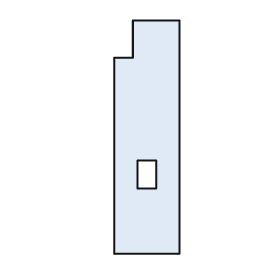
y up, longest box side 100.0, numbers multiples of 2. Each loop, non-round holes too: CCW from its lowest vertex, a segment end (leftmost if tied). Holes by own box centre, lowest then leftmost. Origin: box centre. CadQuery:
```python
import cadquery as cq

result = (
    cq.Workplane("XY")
    .moveTo(-14.0, -50.0)
    .lineTo(14.0, -50.0)
    .lineTo(14.0, 50.0)
    .lineTo(-6.0, 50.0)
    .lineTo(-6.0, 34.0)
    .lineTo(-14.0, 34.0)
    .close()
    .moveTo(-4.0, -22.0)
    .lineTo(4.0, -22.0)
    .lineTo(4.0, -10.0)
    .lineTo(-4.0, -10.0)
    .close()
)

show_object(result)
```